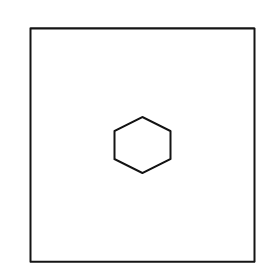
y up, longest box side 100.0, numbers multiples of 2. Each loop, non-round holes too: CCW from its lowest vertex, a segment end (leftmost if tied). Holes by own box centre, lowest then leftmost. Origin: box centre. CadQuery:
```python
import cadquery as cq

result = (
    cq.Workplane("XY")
    .moveTo(-48.0, -50.0)
    .lineTo(48.0, -50.0)
    .lineTo(48.0, 50.0)
    .lineTo(-48.0, 50.0)
    .close()
    .moveTo(0.0, -12.0)
    .lineTo(12.0, -6.0)
    .lineTo(12.0, 6.0)
    .lineTo(0.0, 12.0)
    .lineTo(-12.0, 6.0)
    .lineTo(-12.0, -6.0)
    .close()
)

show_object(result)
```